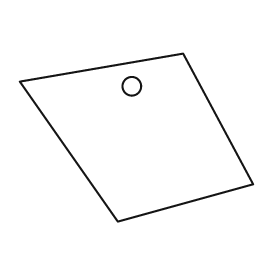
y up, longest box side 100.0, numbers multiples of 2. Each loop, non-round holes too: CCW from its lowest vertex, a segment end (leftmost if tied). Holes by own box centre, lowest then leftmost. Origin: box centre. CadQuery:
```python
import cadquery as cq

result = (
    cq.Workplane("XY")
    .moveTo(-8.0, -36.0)
    .lineTo(50.0, -20.0)
    .lineTo(20.0, 36.0)
    .lineTo(-50.0, 24.0)
    .close()
    .moveTo(-2.0, 22.0)
    .circle(4.0)
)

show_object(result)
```